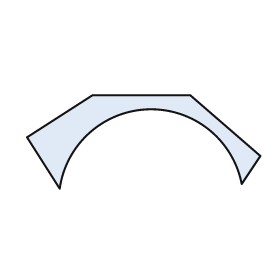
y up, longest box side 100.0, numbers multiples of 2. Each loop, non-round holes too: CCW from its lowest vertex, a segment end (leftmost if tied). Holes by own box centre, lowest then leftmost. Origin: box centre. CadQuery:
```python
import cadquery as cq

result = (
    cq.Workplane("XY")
    .moveTo(-36.0, -20.0)
    .threePointArc((2.0, 14.0), (42.0, -18.0))
    .lineTo(50.0, -6.0)
    .lineTo(20.0, 20.0)
    .lineTo(-22.0, 20.0)
    .lineTo(-50.0, 2.0)
    .close()
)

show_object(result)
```